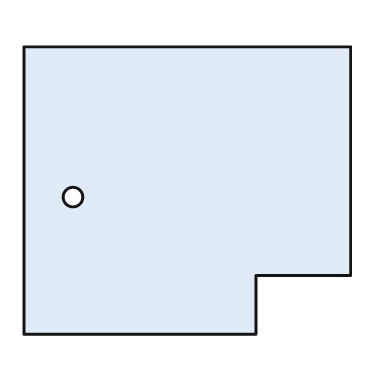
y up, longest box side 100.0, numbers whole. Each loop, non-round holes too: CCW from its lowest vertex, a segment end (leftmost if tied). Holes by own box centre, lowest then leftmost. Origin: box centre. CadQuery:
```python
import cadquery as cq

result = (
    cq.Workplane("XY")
    .moveTo(-50.0, -44.0)
    .lineTo(21.0, -44.0)
    .lineTo(21.0, -26.0)
    .lineTo(50.0, -26.0)
    .lineTo(50.0, 44.0)
    .lineTo(-50.0, 44.0)
    .close()
    .moveTo(-35.0, -2.0)
    .circle(3.0)
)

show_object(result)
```